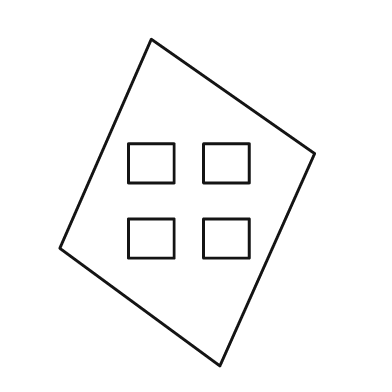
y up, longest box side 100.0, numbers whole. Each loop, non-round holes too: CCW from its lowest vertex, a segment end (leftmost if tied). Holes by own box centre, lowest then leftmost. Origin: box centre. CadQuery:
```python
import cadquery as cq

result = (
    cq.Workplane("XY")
    .moveTo(10.0, -50.0)
    .lineTo(39.0, 15.0)
    .lineTo(-11.0, 50.0)
    .lineTo(-39.0, -14.0)
    .close()
    .moveTo(-18.0, -17.0)
    .lineTo(-4.0, -17.0)
    .lineTo(-4.0, -5.0)
    .lineTo(-18.0, -5.0)
    .close()
    .moveTo(5.0, -17.0)
    .lineTo(19.0, -17.0)
    .lineTo(19.0, -5.0)
    .lineTo(5.0, -5.0)
    .close()
    .moveTo(-18.0, 6.0)
    .lineTo(-4.0, 6.0)
    .lineTo(-4.0, 18.0)
    .lineTo(-18.0, 18.0)
    .close()
    .moveTo(5.0, 6.0)
    .lineTo(19.0, 6.0)
    .lineTo(19.0, 18.0)
    .lineTo(5.0, 18.0)
    .close()
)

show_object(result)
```